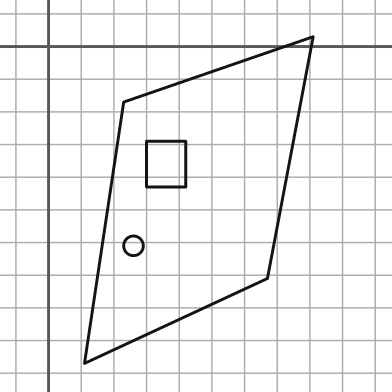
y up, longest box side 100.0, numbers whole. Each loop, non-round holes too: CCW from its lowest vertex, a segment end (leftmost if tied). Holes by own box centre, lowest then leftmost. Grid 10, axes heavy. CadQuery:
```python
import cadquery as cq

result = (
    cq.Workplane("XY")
    .moveTo(11.0, -97.0)
    .lineTo(67.0, -71.0)
    .lineTo(81.0, 3.0)
    .lineTo(23.0, -17.0)
    .close()
    .moveTo(26.0, -61.0)
    .circle(3.0)
    .moveTo(30.0, -43.0)
    .lineTo(42.0, -43.0)
    .lineTo(42.0, -29.0)
    .lineTo(30.0, -29.0)
    .close()
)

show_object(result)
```